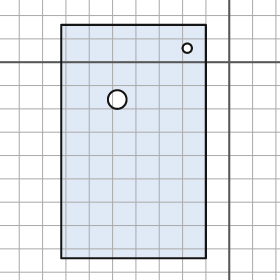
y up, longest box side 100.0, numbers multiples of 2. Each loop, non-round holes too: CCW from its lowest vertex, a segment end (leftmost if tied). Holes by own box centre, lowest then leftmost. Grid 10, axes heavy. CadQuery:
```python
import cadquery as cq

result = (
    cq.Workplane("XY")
    .moveTo(-72.0, -84.0)
    .lineTo(-10.0, -84.0)
    .lineTo(-10.0, 16.0)
    .lineTo(-72.0, 16.0)
    .close()
    .moveTo(-48.0, -16.0)
    .circle(4.0)
    .moveTo(-18.0, 6.0)
    .circle(2.0)
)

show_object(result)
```